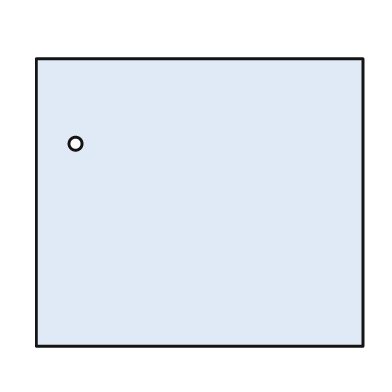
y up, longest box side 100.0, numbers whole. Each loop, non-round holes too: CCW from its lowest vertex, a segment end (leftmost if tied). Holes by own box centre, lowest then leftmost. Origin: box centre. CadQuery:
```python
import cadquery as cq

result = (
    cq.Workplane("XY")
    .moveTo(-50.0, -44.0)
    .lineTo(50.0, -44.0)
    .lineTo(50.0, 44.0)
    .lineTo(-50.0, 44.0)
    .close()
    .moveTo(-38.0, 18.0)
    .circle(2.0)
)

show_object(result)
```